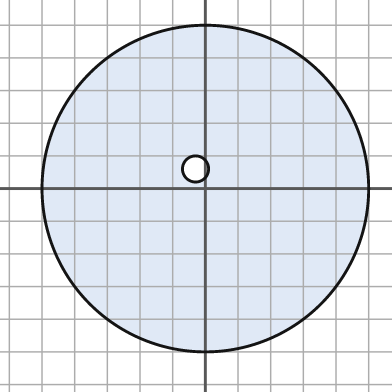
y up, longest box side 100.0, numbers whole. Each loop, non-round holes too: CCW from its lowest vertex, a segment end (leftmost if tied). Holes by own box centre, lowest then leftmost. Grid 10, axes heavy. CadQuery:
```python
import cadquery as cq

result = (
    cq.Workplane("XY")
    .moveTo(0.0, 0.0)
    .circle(50.0)
    .moveTo(-3.0, 6.0)
    .circle(4.0)
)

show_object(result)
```